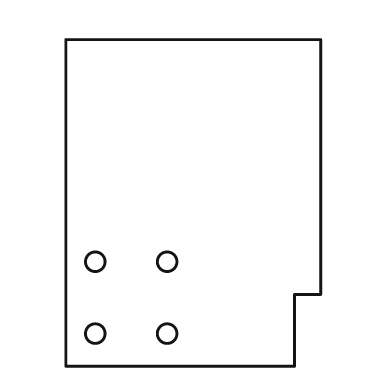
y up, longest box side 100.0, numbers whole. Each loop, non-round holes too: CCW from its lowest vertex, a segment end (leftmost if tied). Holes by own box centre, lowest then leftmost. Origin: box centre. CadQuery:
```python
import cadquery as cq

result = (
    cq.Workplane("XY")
    .moveTo(-39.0, -50.0)
    .lineTo(31.0, -50.0)
    .lineTo(31.0, -28.0)
    .lineTo(39.0, -28.0)
    .lineTo(39.0, 50.0)
    .lineTo(-39.0, 50.0)
    .close()
    .moveTo(-30.0, -40.0)
    .circle(3.0)
    .moveTo(-8.0, -40.0)
    .circle(3.0)
    .moveTo(-30.0, -18.0)
    .circle(3.0)
    .moveTo(-8.0, -18.0)
    .circle(3.0)
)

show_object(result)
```